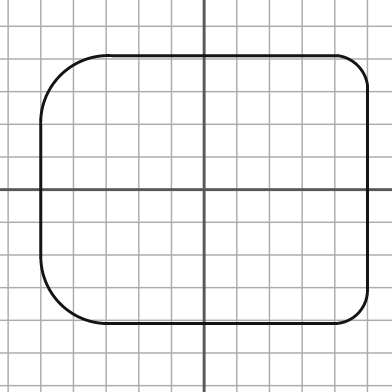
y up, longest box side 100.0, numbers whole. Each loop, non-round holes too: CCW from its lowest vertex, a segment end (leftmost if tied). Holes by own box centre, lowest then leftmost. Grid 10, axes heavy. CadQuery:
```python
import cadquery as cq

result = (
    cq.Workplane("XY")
    .moveTo(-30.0, -41.0)
    .lineTo(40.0, -41.0)
    .threePointArc((47.0, -38.0), (50.0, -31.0))
    .lineTo(50.0, 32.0)
    .threePointArc((47.0, 38.0), (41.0, 41.0))
    .lineTo(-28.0, 41.0)
    .threePointArc((-44.0, 35.0), (-50.0, 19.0))
    .lineTo(-50.0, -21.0)
    .threePointArc((-44.0, -35.0), (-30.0, -41.0))
    .close()
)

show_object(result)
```